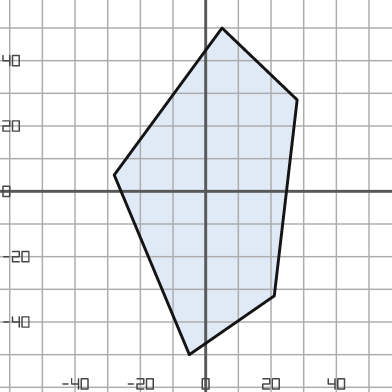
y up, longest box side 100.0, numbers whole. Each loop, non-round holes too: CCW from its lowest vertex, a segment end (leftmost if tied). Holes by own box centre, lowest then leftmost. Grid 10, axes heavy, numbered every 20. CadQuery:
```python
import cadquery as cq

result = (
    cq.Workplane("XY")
    .moveTo(-5.0, -50.0)
    .lineTo(21.0, -32.0)
    .lineTo(28.0, 28.0)
    .lineTo(5.0, 50.0)
    .lineTo(-28.0, 5.0)
    .close()
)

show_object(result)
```